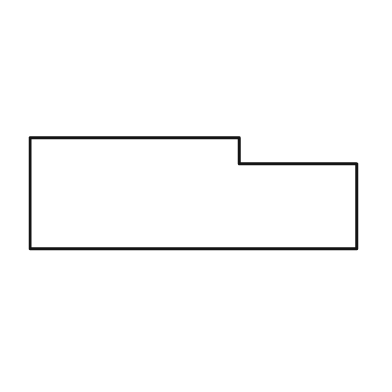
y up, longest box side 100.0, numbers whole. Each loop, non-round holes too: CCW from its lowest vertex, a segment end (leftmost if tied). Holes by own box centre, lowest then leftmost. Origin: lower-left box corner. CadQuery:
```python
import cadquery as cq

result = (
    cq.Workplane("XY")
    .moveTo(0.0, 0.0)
    .lineTo(100.0, 0.0)
    .lineTo(100.0, 26.0)
    .lineTo(64.0, 26.0)
    .lineTo(64.0, 34.0)
    .lineTo(0.0, 34.0)
    .close()
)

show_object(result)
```